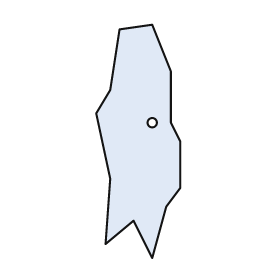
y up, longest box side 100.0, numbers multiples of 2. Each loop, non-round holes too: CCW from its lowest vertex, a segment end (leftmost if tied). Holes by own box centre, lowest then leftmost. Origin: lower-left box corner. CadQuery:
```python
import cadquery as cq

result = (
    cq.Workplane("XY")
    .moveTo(24.0, 0.0)
    .lineTo(30.0, 22.0)
    .lineTo(36.0, 30.0)
    .lineTo(36.0, 50.0)
    .lineTo(32.0, 58.0)
    .lineTo(32.0, 80.0)
    .lineTo(24.0, 100.0)
    .lineTo(10.0, 98.0)
    .lineTo(6.0, 72.0)
    .lineTo(0.0, 62.0)
    .lineTo(6.0, 34.0)
    .lineTo(4.0, 6.0)
    .lineTo(16.0, 16.0)
    .close()
    .moveTo(24.0, 58.0)
    .circle(2.0)
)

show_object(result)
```